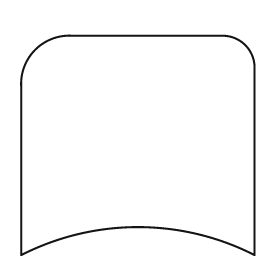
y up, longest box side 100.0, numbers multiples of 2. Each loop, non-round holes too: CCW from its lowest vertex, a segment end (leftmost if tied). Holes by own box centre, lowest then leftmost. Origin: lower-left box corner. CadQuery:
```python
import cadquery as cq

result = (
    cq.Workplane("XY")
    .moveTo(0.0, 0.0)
    .threePointArc((50.0, 12.0), (100.0, 0.0))
    .lineTo(100.0, 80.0)
    .threePointArc((96.0, 90.0), (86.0, 94.0))
    .lineTo(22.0, 94.0)
    .threePointArc((6.0, 88.0), (0.0, 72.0))
    .close()
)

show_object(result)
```